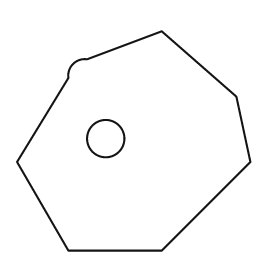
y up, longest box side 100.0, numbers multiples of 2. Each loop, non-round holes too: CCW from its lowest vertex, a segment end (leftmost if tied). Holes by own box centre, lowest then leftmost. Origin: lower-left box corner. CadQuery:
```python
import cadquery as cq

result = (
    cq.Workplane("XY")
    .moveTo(22.0, 0.0)
    .lineTo(62.0, 0.0)
    .lineTo(100.0, 38.0)
    .lineTo(94.0, 66.0)
    .lineTo(62.0, 94.0)
    .lineTo(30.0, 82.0)
    .threePointArc((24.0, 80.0), (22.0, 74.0))
    .lineTo(0.0, 38.0)
    .close()
    .moveTo(38.0, 48.0)
    .circle(8.0)
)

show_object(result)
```